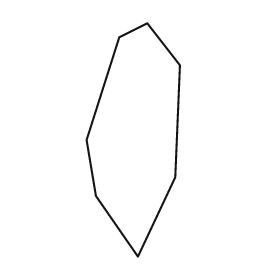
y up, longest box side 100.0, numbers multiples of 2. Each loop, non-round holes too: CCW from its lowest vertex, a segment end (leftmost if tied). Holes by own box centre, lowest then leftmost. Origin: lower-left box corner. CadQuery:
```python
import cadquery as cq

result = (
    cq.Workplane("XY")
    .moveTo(22.0, 0.0)
    .lineTo(38.0, 34.0)
    .lineTo(40.0, 82.0)
    .lineTo(26.0, 100.0)
    .lineTo(14.0, 94.0)
    .lineTo(0.0, 50.0)
    .lineTo(4.0, 26.0)
    .close()
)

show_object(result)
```